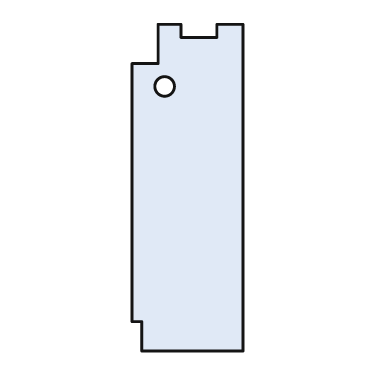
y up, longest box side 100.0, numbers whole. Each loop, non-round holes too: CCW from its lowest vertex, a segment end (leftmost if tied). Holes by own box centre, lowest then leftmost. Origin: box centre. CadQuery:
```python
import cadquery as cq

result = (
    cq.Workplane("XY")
    .moveTo(-14.0, -50.0)
    .lineTo(17.0, -50.0)
    .lineTo(17.0, 50.0)
    .lineTo(9.0, 50.0)
    .lineTo(9.0, 46.0)
    .lineTo(-2.0, 46.0)
    .lineTo(-2.0, 50.0)
    .lineTo(-9.0, 50.0)
    .lineTo(-9.0, 38.0)
    .lineTo(-17.0, 38.0)
    .lineTo(-17.0, -41.0)
    .lineTo(-14.0, -41.0)
    .close()
    .moveTo(-7.0, 31.0)
    .circle(3.0)
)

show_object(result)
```